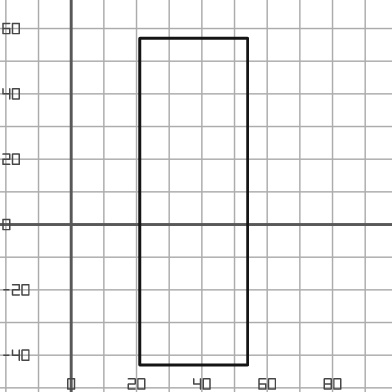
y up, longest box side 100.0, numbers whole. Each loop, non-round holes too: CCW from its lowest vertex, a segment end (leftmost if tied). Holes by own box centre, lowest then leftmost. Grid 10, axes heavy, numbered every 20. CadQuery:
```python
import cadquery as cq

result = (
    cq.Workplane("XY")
    .moveTo(21.0, -43.0)
    .lineTo(54.0, -43.0)
    .lineTo(54.0, 57.0)
    .lineTo(21.0, 57.0)
    .close()
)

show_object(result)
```